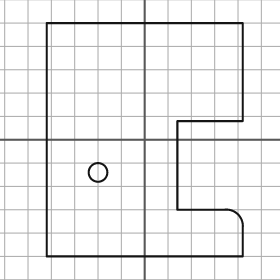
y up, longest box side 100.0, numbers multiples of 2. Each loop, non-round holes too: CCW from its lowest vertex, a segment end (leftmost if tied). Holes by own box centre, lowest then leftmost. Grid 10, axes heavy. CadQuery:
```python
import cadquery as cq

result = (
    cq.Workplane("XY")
    .moveTo(-42.0, -50.0)
    .lineTo(42.0, -50.0)
    .lineTo(42.0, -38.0)
    .threePointArc((40.0, -32.0), (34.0, -30.0))
    .lineTo(14.0, -30.0)
    .lineTo(14.0, 8.0)
    .lineTo(42.0, 8.0)
    .lineTo(42.0, 50.0)
    .lineTo(-42.0, 50.0)
    .close()
    .moveTo(-20.0, -14.0)
    .circle(4.0)
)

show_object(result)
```